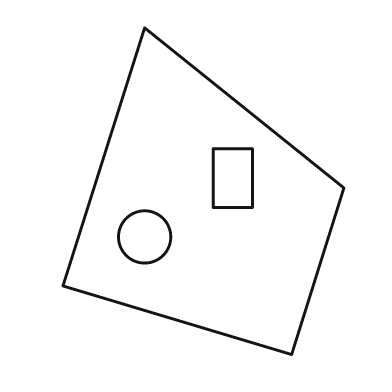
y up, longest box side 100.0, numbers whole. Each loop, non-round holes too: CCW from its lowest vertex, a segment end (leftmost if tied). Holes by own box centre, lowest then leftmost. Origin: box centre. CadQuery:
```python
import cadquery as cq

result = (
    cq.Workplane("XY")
    .moveTo(27.0, -50.0)
    .lineTo(43.0, 1.0)
    .lineTo(-18.0, 50.0)
    .lineTo(-43.0, -29.0)
    .close()
    .moveTo(-18.0, -14.0)
    .circle(8.0)
    .moveTo(3.0, -5.0)
    .lineTo(15.0, -5.0)
    .lineTo(15.0, 13.0)
    .lineTo(3.0, 13.0)
    .close()
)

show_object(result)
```